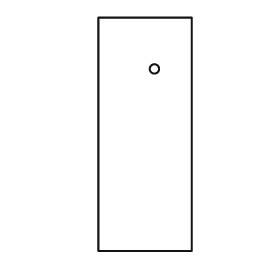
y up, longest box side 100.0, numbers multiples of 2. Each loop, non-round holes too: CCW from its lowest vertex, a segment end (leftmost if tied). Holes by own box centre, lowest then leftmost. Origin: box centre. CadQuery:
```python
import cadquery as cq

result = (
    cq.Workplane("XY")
    .moveTo(-20.0, -50.0)
    .lineTo(20.0, -50.0)
    .lineTo(20.0, 50.0)
    .lineTo(-20.0, 50.0)
    .close()
    .moveTo(4.0, 28.0)
    .circle(2.0)
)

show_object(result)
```